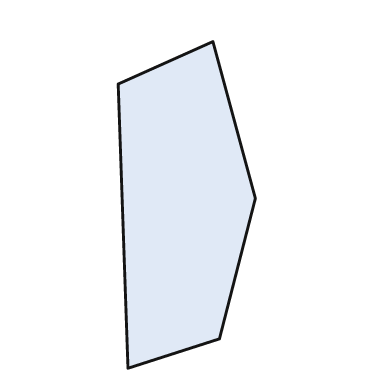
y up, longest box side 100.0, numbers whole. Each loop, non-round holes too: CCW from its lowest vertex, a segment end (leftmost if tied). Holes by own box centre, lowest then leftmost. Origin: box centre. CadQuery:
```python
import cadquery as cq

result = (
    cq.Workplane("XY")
    .moveTo(-18.0, -50.0)
    .lineTo(10.0, -41.0)
    .lineTo(21.0, 2.0)
    .lineTo(8.0, 50.0)
    .lineTo(-21.0, 37.0)
    .close()
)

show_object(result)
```